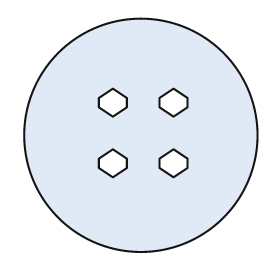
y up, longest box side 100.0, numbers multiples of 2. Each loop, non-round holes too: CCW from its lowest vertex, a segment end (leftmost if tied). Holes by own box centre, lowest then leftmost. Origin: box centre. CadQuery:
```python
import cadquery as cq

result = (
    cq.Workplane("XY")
    .moveTo(0.0, 0.0)
    .circle(50.0)
    .moveTo(-12.0, -18.0)
    .lineTo(-6.0, -14.0)
    .lineTo(-6.0, -10.0)
    .lineTo(-12.0, -6.0)
    .lineTo(-18.0, -10.0)
    .lineTo(-18.0, -14.0)
    .close()
    .moveTo(14.0, -18.0)
    .lineTo(20.0, -14.0)
    .lineTo(20.0, -10.0)
    .lineTo(14.0, -6.0)
    .lineTo(8.0, -10.0)
    .lineTo(8.0, -14.0)
    .close()
    .moveTo(-12.0, 8.0)
    .lineTo(-6.0, 12.0)
    .lineTo(-6.0, 16.0)
    .lineTo(-12.0, 20.0)
    .lineTo(-18.0, 16.0)
    .lineTo(-18.0, 12.0)
    .close()
    .moveTo(14.0, 8.0)
    .lineTo(20.0, 12.0)
    .lineTo(20.0, 16.0)
    .lineTo(14.0, 20.0)
    .lineTo(8.0, 16.0)
    .lineTo(8.0, 12.0)
    .close()
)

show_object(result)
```